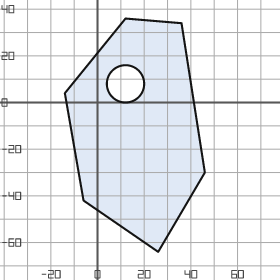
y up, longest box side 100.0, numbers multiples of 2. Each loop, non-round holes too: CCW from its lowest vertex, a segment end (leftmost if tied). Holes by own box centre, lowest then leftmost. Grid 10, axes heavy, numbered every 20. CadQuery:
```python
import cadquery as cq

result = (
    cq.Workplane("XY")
    .moveTo(26.0, -64.0)
    .lineTo(46.0, -30.0)
    .lineTo(36.0, 34.0)
    .lineTo(12.0, 36.0)
    .lineTo(-14.0, 4.0)
    .lineTo(-6.0, -42.0)
    .close()
    .moveTo(12.0, 8.0)
    .circle(8.0)
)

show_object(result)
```